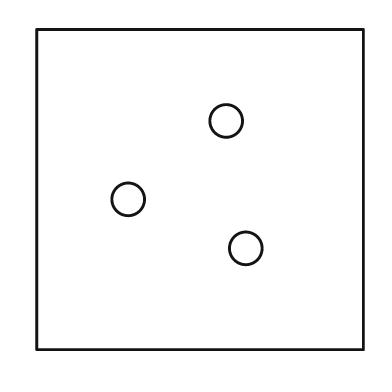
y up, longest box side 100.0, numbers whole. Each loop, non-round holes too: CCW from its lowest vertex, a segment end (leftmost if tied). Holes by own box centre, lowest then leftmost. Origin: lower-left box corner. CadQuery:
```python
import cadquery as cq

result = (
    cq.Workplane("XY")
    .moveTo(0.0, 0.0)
    .lineTo(100.0, 0.0)
    .lineTo(100.0, 98.0)
    .lineTo(0.0, 98.0)
    .close()
    .moveTo(64.0, 31.0)
    .circle(5.0)
    .moveTo(28.0, 46.0)
    .circle(5.0)
    .moveTo(58.0, 70.0)
    .circle(5.0)
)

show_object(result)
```